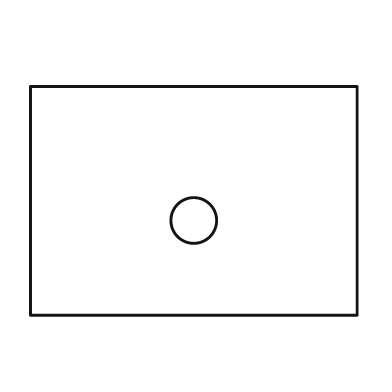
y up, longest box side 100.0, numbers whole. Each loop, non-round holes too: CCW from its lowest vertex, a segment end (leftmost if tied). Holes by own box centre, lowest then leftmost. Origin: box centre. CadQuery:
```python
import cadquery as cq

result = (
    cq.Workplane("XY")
    .moveTo(-50.0, -35.0)
    .lineTo(50.0, -35.0)
    .lineTo(50.0, 35.0)
    .lineTo(-50.0, 35.0)
    .close()
    .moveTo(0.0, -6.0)
    .circle(7.0)
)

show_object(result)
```